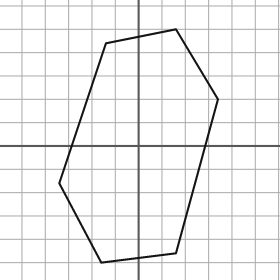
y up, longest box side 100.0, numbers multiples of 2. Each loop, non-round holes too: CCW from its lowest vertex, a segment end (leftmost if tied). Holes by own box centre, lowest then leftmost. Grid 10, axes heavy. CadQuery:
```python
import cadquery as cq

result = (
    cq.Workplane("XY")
    .moveTo(-16.0, -50.0)
    .lineTo(16.0, -46.0)
    .lineTo(34.0, 20.0)
    .lineTo(16.0, 50.0)
    .lineTo(-14.0, 44.0)
    .lineTo(-34.0, -16.0)
    .close()
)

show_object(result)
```